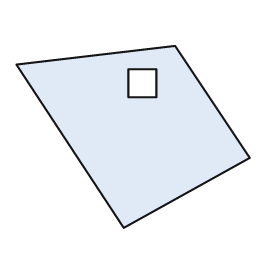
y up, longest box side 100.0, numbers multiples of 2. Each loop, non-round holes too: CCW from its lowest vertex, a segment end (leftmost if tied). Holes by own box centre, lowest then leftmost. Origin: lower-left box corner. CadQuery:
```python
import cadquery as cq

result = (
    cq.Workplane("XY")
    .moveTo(46.0, 0.0)
    .lineTo(100.0, 30.0)
    .lineTo(68.0, 78.0)
    .lineTo(0.0, 70.0)
    .close()
    .moveTo(48.0, 56.0)
    .lineTo(60.0, 56.0)
    .lineTo(60.0, 68.0)
    .lineTo(48.0, 68.0)
    .close()
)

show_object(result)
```